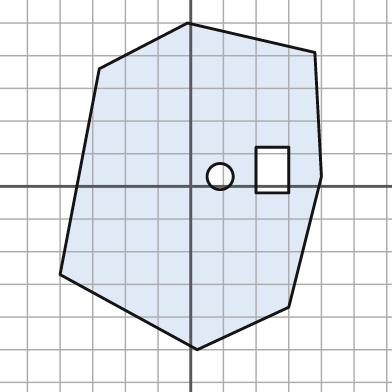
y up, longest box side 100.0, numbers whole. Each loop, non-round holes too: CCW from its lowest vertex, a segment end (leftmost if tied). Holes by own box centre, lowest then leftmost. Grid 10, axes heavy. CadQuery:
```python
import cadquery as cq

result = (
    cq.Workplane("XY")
    .moveTo(2.0, -50.0)
    .lineTo(30.0, -37.0)
    .lineTo(40.0, 3.0)
    .lineTo(38.0, 41.0)
    .lineTo(-1.0, 50.0)
    .lineTo(-28.0, 36.0)
    .lineTo(-40.0, -27.0)
    .close()
    .moveTo(9.0, 3.0)
    .circle(4.0)
    .moveTo(20.0, -2.0)
    .lineTo(30.0, -2.0)
    .lineTo(30.0, 12.0)
    .lineTo(20.0, 12.0)
    .close()
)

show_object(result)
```